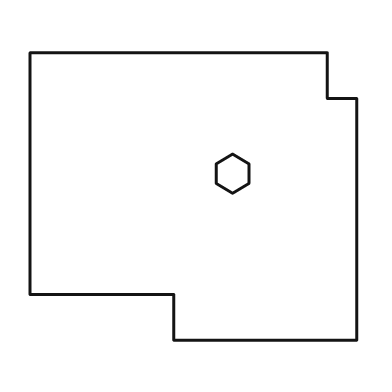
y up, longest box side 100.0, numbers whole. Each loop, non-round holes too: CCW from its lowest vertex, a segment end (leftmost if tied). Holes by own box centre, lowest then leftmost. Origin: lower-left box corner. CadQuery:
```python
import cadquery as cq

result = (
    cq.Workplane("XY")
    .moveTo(44.0, 0.0)
    .lineTo(100.0, 0.0)
    .lineTo(100.0, 74.0)
    .lineTo(91.0, 74.0)
    .lineTo(91.0, 88.0)
    .lineTo(0.0, 88.0)
    .lineTo(0.0, 14.0)
    .lineTo(44.0, 14.0)
    .close()
    .moveTo(62.0, 45.0)
    .lineTo(67.0, 48.0)
    .lineTo(67.0, 54.0)
    .lineTo(62.0, 57.0)
    .lineTo(57.0, 54.0)
    .lineTo(57.0, 48.0)
    .close()
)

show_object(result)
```